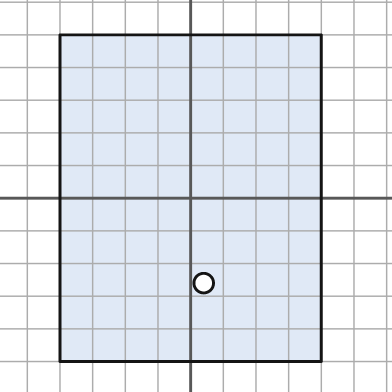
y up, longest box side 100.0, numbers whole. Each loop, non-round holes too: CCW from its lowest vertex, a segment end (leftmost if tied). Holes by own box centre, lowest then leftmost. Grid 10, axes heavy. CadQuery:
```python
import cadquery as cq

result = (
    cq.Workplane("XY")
    .moveTo(-40.0, -50.0)
    .lineTo(40.0, -50.0)
    .lineTo(40.0, 50.0)
    .lineTo(-40.0, 50.0)
    .close()
    .moveTo(4.0, -26.0)
    .circle(3.0)
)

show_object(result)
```